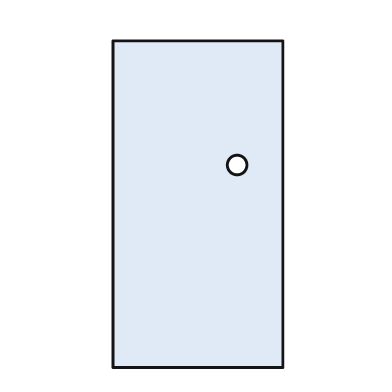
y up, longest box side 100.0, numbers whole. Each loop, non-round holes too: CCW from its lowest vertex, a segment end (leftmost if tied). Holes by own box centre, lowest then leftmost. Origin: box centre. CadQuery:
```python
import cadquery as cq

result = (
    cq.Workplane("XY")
    .moveTo(-26.0, -50.0)
    .lineTo(26.0, -50.0)
    .lineTo(26.0, 50.0)
    .lineTo(-26.0, 50.0)
    .close()
    .moveTo(12.0, 12.0)
    .circle(3.0)
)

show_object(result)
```